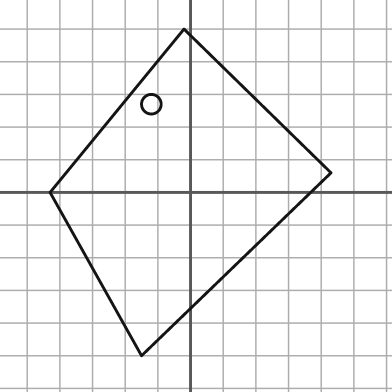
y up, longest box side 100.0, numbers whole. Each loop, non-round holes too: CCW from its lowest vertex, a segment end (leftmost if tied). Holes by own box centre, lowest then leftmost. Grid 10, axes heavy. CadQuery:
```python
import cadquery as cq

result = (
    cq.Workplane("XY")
    .moveTo(-15.0, -50.0)
    .lineTo(43.0, 6.0)
    .lineTo(-2.0, 50.0)
    .lineTo(-43.0, 0.0)
    .close()
    .moveTo(-12.0, 27.0)
    .circle(3.0)
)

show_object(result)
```